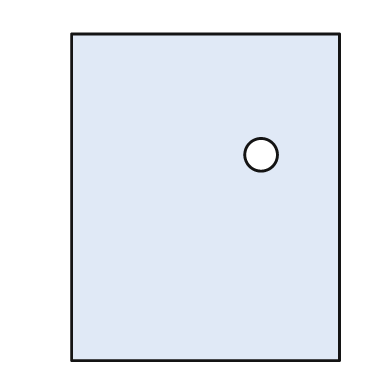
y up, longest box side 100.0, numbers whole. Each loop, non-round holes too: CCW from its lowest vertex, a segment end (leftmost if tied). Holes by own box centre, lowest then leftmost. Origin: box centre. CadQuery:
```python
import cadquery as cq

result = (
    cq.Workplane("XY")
    .moveTo(-41.0, -50.0)
    .lineTo(41.0, -50.0)
    .lineTo(41.0, 50.0)
    .lineTo(-41.0, 50.0)
    .close()
    .moveTo(17.0, 13.0)
    .circle(5.0)
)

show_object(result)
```